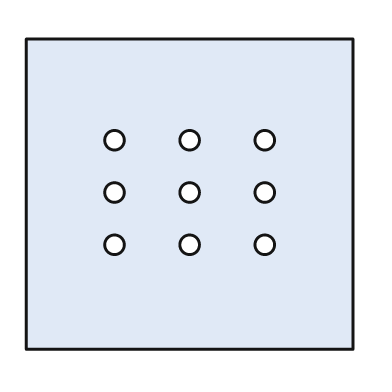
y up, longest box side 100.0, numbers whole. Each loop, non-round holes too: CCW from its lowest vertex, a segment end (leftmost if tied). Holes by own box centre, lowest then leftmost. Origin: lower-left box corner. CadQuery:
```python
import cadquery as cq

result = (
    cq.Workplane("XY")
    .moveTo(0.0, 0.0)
    .lineTo(100.0, 0.0)
    .lineTo(100.0, 95.0)
    .lineTo(0.0, 95.0)
    .close()
    .moveTo(27.0, 32.0)
    .circle(3.0)
    .moveTo(50.0, 32.0)
    .circle(3.0)
    .moveTo(73.0, 32.0)
    .circle(3.0)
    .moveTo(27.0, 48.0)
    .circle(3.0)
    .moveTo(50.0, 48.0)
    .circle(3.0)
    .moveTo(73.0, 48.0)
    .circle(3.0)
    .moveTo(27.0, 64.0)
    .circle(3.0)
    .moveTo(50.0, 64.0)
    .circle(3.0)
    .moveTo(73.0, 64.0)
    .circle(3.0)
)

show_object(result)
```